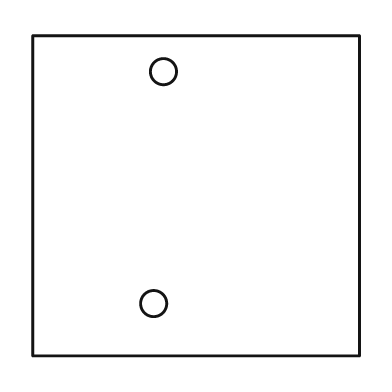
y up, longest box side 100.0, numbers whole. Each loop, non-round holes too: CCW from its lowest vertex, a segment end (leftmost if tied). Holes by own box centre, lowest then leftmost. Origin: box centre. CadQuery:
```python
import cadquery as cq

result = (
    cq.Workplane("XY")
    .moveTo(-50.0, -49.0)
    .lineTo(50.0, -49.0)
    .lineTo(50.0, 49.0)
    .lineTo(-50.0, 49.0)
    .close()
    .moveTo(-13.0, -33.0)
    .circle(4.0)
    .moveTo(-10.0, 38.0)
    .circle(4.0)
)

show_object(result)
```